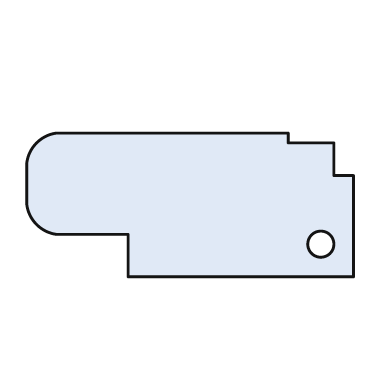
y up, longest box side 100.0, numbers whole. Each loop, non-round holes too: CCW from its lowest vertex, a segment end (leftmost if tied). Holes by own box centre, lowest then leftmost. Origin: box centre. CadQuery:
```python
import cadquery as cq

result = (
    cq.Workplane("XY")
    .moveTo(-19.0, -22.0)
    .lineTo(50.0, -22.0)
    .lineTo(50.0, 9.0)
    .lineTo(44.0, 9.0)
    .lineTo(44.0, 19.0)
    .lineTo(30.0, 19.0)
    .lineTo(30.0, 22.0)
    .lineTo(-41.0, 22.0)
    .threePointArc((-47.0, 19.0), (-50.0, 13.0))
    .lineTo(-50.0, 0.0)
    .threePointArc((-47.0, -6.0), (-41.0, -9.0))
    .lineTo(-19.0, -9.0)
    .close()
    .moveTo(40.0, -12.0)
    .circle(4.0)
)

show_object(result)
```